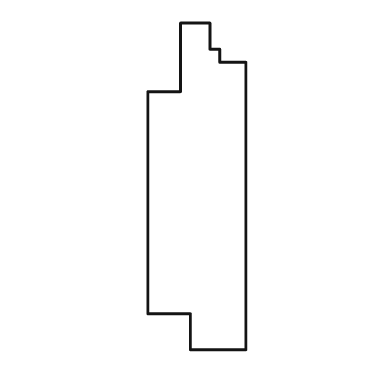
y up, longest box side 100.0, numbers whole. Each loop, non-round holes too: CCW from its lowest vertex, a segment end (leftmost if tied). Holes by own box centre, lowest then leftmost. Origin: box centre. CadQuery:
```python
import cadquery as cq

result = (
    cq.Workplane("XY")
    .moveTo(-2.0, -50.0)
    .lineTo(15.0, -50.0)
    .lineTo(15.0, 38.0)
    .lineTo(7.0, 38.0)
    .lineTo(7.0, 42.0)
    .lineTo(4.0, 42.0)
    .lineTo(4.0, 50.0)
    .lineTo(-5.0, 50.0)
    .lineTo(-5.0, 29.0)
    .lineTo(-15.0, 29.0)
    .lineTo(-15.0, -39.0)
    .lineTo(-2.0, -39.0)
    .close()
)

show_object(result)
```